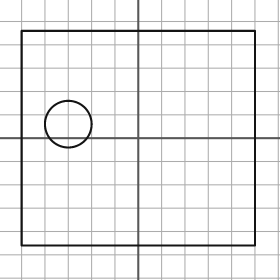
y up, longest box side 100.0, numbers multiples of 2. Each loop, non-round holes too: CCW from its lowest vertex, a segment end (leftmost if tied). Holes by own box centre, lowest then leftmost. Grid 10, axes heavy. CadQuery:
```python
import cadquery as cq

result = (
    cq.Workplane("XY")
    .moveTo(-50.0, -46.0)
    .lineTo(50.0, -46.0)
    .lineTo(50.0, 46.0)
    .lineTo(-50.0, 46.0)
    .close()
    .moveTo(-30.0, 6.0)
    .circle(10.0)
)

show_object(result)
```